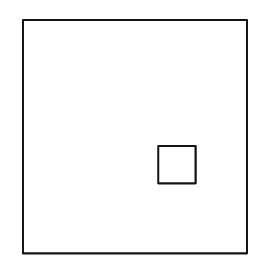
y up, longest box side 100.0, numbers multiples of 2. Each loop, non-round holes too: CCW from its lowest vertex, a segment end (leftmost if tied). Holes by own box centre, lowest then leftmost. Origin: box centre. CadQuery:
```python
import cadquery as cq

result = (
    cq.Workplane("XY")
    .moveTo(-48.0, -50.0)
    .lineTo(48.0, -50.0)
    .lineTo(48.0, 50.0)
    .lineTo(-48.0, 50.0)
    .close()
    .moveTo(10.0, -20.0)
    .lineTo(26.0, -20.0)
    .lineTo(26.0, -4.0)
    .lineTo(10.0, -4.0)
    .close()
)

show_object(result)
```